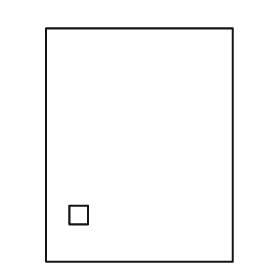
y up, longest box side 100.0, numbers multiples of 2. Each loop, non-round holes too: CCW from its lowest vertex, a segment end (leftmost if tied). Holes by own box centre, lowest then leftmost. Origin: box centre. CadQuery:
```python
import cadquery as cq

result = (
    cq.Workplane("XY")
    .moveTo(-40.0, -50.0)
    .lineTo(40.0, -50.0)
    .lineTo(40.0, 50.0)
    .lineTo(-40.0, 50.0)
    .close()
    .moveTo(-30.0, -34.0)
    .lineTo(-22.0, -34.0)
    .lineTo(-22.0, -26.0)
    .lineTo(-30.0, -26.0)
    .close()
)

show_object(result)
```